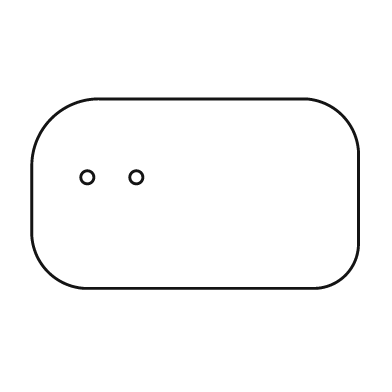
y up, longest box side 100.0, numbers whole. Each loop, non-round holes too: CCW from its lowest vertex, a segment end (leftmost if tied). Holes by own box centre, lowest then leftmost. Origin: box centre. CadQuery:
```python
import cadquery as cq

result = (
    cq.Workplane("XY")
    .moveTo(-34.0, -29.0)
    .lineTo(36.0, -29.0)
    .threePointArc((46.0, -25.0), (50.0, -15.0))
    .lineTo(50.0, 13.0)
    .threePointArc((45.0, 24.0), (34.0, 29.0))
    .lineTo(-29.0, 29.0)
    .threePointArc((-44.0, 23.0), (-50.0, 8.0))
    .lineTo(-50.0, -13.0)
    .threePointArc((-45.0, -24.0), (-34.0, -29.0))
    .close()
    .moveTo(-33.0, 5.0)
    .circle(2.0)
    .moveTo(-18.0, 5.0)
    .circle(2.0)
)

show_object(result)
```